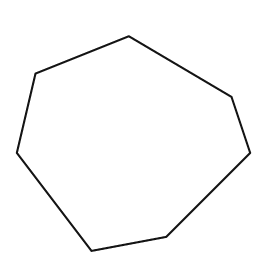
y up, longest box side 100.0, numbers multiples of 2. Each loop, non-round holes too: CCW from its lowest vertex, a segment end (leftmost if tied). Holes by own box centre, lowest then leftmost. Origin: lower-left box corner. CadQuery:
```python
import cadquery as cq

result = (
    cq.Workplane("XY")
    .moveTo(32.0, 0.0)
    .lineTo(64.0, 6.0)
    .lineTo(100.0, 42.0)
    .lineTo(92.0, 66.0)
    .lineTo(48.0, 92.0)
    .lineTo(8.0, 76.0)
    .lineTo(0.0, 42.0)
    .close()
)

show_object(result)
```